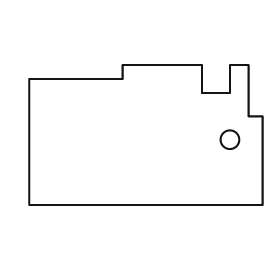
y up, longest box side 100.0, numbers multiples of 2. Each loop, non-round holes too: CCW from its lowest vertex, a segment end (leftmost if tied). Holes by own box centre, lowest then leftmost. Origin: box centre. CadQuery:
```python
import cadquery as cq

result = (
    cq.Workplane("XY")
    .moveTo(-50.0, -30.0)
    .lineTo(50.0, -30.0)
    .lineTo(50.0, 8.0)
    .lineTo(44.0, 8.0)
    .lineTo(44.0, 30.0)
    .lineTo(36.0, 30.0)
    .lineTo(36.0, 18.0)
    .lineTo(24.0, 18.0)
    .lineTo(24.0, 30.0)
    .lineTo(-10.0, 30.0)
    .lineTo(-10.0, 24.0)
    .lineTo(-50.0, 24.0)
    .close()
    .moveTo(36.0, -2.0)
    .circle(4.0)
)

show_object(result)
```